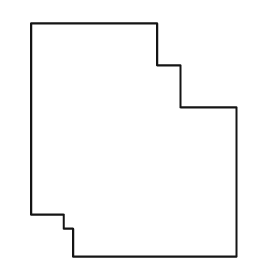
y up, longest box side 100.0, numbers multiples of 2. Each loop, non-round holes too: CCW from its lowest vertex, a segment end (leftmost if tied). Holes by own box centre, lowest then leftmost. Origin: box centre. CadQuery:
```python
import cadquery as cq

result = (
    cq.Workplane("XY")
    .moveTo(-26.0, -50.0)
    .lineTo(44.0, -50.0)
    .lineTo(44.0, 14.0)
    .lineTo(20.0, 14.0)
    .lineTo(20.0, 32.0)
    .lineTo(10.0, 32.0)
    .lineTo(10.0, 50.0)
    .lineTo(-44.0, 50.0)
    .lineTo(-44.0, -32.0)
    .lineTo(-30.0, -32.0)
    .lineTo(-30.0, -38.0)
    .lineTo(-26.0, -38.0)
    .close()
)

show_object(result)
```